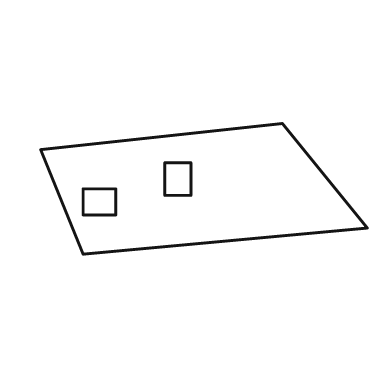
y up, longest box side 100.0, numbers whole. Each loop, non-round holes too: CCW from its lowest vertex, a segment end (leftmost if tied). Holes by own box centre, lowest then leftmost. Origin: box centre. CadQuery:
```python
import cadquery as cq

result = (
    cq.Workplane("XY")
    .moveTo(-37.0, -20.0)
    .lineTo(50.0, -12.0)
    .lineTo(24.0, 20.0)
    .lineTo(-50.0, 12.0)
    .close()
    .moveTo(-37.0, -8.0)
    .lineTo(-27.0, -8.0)
    .lineTo(-27.0, 0.0)
    .lineTo(-37.0, 0.0)
    .close()
    .moveTo(-12.0, -2.0)
    .lineTo(-4.0, -2.0)
    .lineTo(-4.0, 8.0)
    .lineTo(-12.0, 8.0)
    .close()
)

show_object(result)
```